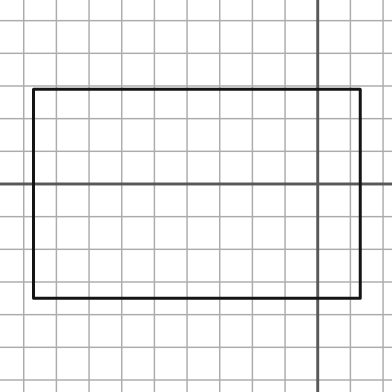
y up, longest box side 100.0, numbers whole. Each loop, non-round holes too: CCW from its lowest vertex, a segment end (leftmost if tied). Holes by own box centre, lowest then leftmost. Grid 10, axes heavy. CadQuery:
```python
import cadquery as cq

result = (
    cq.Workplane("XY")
    .moveTo(-87.0, -35.0)
    .lineTo(13.0, -35.0)
    .lineTo(13.0, 29.0)
    .lineTo(-87.0, 29.0)
    .close()
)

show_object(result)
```